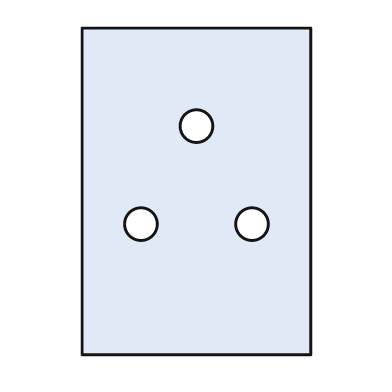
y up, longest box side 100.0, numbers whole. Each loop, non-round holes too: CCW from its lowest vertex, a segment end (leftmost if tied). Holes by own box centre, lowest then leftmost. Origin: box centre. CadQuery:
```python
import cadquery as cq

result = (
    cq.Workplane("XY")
    .moveTo(-35.0, -50.0)
    .lineTo(35.0, -50.0)
    .lineTo(35.0, 50.0)
    .lineTo(-35.0, 50.0)
    .close()
    .moveTo(-17.0, -10.0)
    .circle(5.0)
    .moveTo(17.0, -10.0)
    .circle(5.0)
    .moveTo(0.0, 20.0)
    .circle(5.0)
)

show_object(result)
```